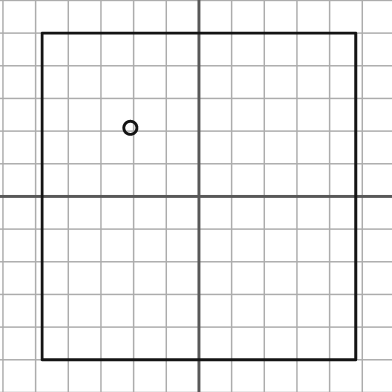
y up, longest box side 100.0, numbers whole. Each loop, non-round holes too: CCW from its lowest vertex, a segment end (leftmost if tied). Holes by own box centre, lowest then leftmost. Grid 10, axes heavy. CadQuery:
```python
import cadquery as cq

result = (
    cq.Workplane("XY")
    .moveTo(-48.0, -50.0)
    .lineTo(48.0, -50.0)
    .lineTo(48.0, 50.0)
    .lineTo(-48.0, 50.0)
    .close()
    .moveTo(-21.0, 21.0)
    .circle(2.0)
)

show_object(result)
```